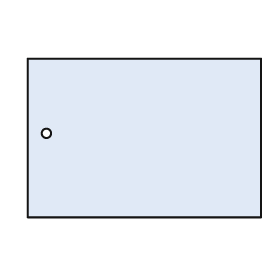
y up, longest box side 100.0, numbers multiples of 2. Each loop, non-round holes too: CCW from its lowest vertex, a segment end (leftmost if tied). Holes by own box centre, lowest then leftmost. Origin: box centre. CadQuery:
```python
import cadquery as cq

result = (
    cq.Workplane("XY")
    .moveTo(-50.0, -34.0)
    .lineTo(50.0, -34.0)
    .lineTo(50.0, 34.0)
    .lineTo(-50.0, 34.0)
    .close()
    .moveTo(-42.0, 2.0)
    .circle(2.0)
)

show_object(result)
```